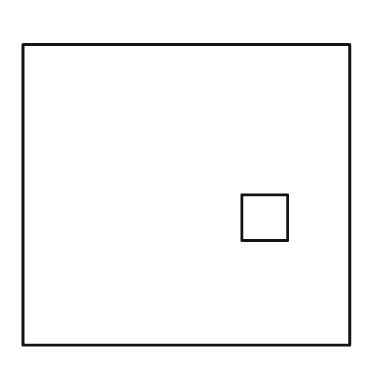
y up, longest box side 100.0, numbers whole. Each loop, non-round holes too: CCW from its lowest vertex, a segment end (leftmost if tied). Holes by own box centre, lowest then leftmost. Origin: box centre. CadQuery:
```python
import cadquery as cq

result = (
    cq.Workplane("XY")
    .moveTo(-50.0, -46.0)
    .lineTo(50.0, -46.0)
    .lineTo(50.0, 46.0)
    .lineTo(-50.0, 46.0)
    .close()
    .moveTo(17.0, -14.0)
    .lineTo(31.0, -14.0)
    .lineTo(31.0, 0.0)
    .lineTo(17.0, 0.0)
    .close()
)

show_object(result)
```